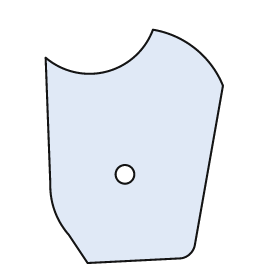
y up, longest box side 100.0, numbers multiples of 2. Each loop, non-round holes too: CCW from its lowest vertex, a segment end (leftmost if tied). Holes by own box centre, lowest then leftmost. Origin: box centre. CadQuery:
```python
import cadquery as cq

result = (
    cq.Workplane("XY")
    .moveTo(-20.0, -50.0)
    .lineTo(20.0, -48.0)
    .threePointArc((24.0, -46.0), (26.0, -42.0))
    .lineTo(38.0, 26.0)
    .threePointArc((26.0, 42.0), (8.0, 50.0))
    .threePointArc((-12.0, 32.0), (-38.0, 38.0))
    .lineTo(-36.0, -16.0)
    .threePointArc((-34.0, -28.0), (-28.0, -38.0))
    .close()
    .moveTo(-4.0, -12.0)
    .circle(4.0)
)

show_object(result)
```